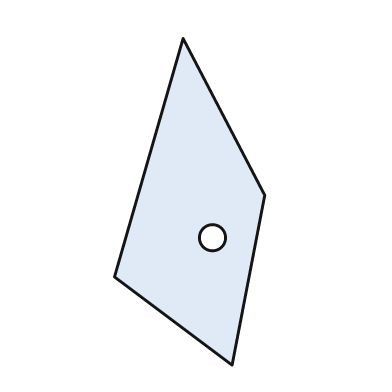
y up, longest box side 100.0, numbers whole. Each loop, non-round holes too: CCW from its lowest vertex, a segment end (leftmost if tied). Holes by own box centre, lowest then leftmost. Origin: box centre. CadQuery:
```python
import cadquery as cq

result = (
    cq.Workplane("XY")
    .moveTo(13.0, -50.0)
    .lineTo(23.0, 2.0)
    .lineTo(-2.0, 50.0)
    .lineTo(-23.0, -23.0)
    .close()
    .moveTo(7.0, -11.0)
    .circle(4.0)
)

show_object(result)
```